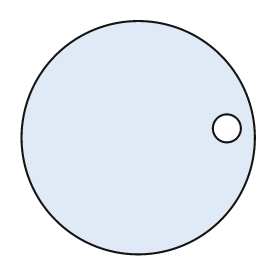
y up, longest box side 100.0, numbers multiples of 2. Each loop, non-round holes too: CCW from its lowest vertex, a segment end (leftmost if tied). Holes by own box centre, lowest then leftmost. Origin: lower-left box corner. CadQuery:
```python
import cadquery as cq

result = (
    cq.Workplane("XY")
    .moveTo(50.0, 50.0)
    .circle(50.0)
    .moveTo(88.0, 54.0)
    .circle(6.0)
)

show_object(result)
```